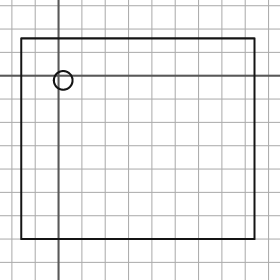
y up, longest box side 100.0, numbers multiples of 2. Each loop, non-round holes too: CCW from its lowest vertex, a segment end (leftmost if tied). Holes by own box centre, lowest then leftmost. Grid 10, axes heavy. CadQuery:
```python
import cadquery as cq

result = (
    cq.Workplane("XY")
    .moveTo(-16.0, -70.0)
    .lineTo(84.0, -70.0)
    .lineTo(84.0, 16.0)
    .lineTo(-16.0, 16.0)
    .close()
    .moveTo(2.0, -2.0)
    .circle(4.0)
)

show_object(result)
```